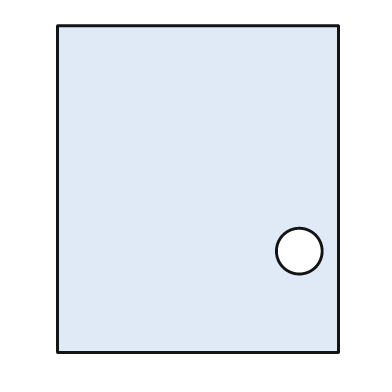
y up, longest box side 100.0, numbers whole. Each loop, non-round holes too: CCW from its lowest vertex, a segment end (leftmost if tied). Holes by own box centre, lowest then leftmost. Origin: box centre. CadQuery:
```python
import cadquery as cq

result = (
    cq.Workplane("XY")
    .moveTo(-43.0, -50.0)
    .lineTo(43.0, -50.0)
    .lineTo(43.0, 50.0)
    .lineTo(-43.0, 50.0)
    .close()
    .moveTo(31.0, -19.0)
    .circle(7.0)
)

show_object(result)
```